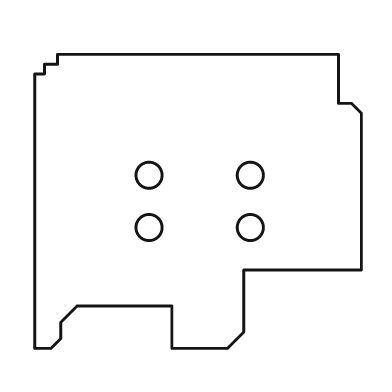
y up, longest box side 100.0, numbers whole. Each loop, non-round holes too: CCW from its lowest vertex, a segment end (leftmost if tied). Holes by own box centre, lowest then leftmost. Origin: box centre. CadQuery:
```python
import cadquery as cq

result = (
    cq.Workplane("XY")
    .moveTo(-50.0, -45.0)
    .lineTo(-45.0, -45.0)
    .lineTo(-42.0, -42.0)
    .lineTo(-42.0, -37.0)
    .lineTo(-37.0, -32.0)
    .lineTo(-8.0, -32.0)
    .lineTo(-8.0, -45.0)
    .lineTo(9.0, -45.0)
    .lineTo(14.0, -40.0)
    .lineTo(14.0, -21.0)
    .lineTo(50.0, -21.0)
    .lineTo(50.0, 27.0)
    .lineTo(47.0, 30.0)
    .lineTo(43.0, 30.0)
    .lineTo(43.0, 45.0)
    .lineTo(-43.0, 45.0)
    .lineTo(-43.0, 42.0)
    .lineTo(-47.0, 42.0)
    .lineTo(-47.0, 39.0)
    .lineTo(-50.0, 39.0)
    .close()
    .moveTo(-15.0, -8.0)
    .circle(4.0)
    .moveTo(16.0, -8.0)
    .circle(4.0)
    .moveTo(-15.0, 8.0)
    .circle(4.0)
    .moveTo(16.0, 8.0)
    .circle(4.0)
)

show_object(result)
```